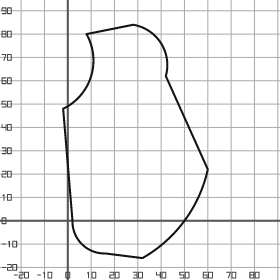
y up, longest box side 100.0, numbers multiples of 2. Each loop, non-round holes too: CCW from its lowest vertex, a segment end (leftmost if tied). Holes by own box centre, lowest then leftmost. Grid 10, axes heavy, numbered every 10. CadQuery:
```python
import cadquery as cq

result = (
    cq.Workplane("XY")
    .moveTo(32.0, -16.0)
    .threePointArc((50.0, 0.0), (60.0, 22.0))
    .lineTo(42.0, 62.0)
    .threePointArc((40.0, 76.0), (28.0, 84.0))
    .lineTo(8.0, 80.0)
    .threePointArc((10.0, 62.0), (-2.0, 48.0))
    .lineTo(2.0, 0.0)
    .threePointArc((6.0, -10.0), (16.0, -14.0))
    .close()
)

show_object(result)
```